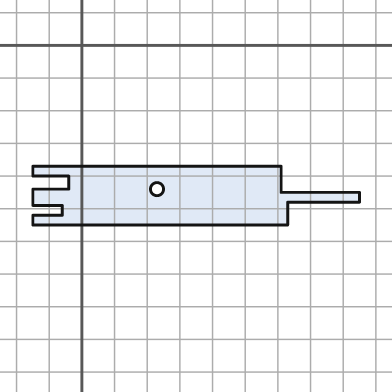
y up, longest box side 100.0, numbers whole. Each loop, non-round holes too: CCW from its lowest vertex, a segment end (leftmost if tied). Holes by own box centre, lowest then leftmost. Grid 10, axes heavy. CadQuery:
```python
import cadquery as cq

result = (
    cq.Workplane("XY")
    .moveTo(-15.0, -55.0)
    .lineTo(63.0, -55.0)
    .lineTo(63.0, -48.0)
    .lineTo(85.0, -48.0)
    .lineTo(85.0, -45.0)
    .lineTo(61.0, -45.0)
    .lineTo(61.0, -37.0)
    .lineTo(-15.0, -37.0)
    .lineTo(-15.0, -40.0)
    .lineTo(-4.0, -40.0)
    .lineTo(-4.0, -44.0)
    .lineTo(-15.0, -44.0)
    .lineTo(-15.0, -49.0)
    .lineTo(-6.0, -49.0)
    .lineTo(-6.0, -52.0)
    .lineTo(-15.0, -52.0)
    .close()
    .moveTo(23.0, -44.0)
    .circle(2.0)
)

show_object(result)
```